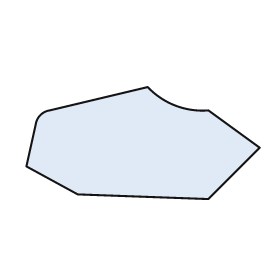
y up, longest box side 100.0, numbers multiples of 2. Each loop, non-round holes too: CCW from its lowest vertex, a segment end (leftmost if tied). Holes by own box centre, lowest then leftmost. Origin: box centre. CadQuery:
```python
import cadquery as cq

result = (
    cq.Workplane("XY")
    .moveTo(28.0, -24.0)
    .lineTo(50.0, -2.0)
    .lineTo(28.0, 14.0)
    .threePointArc((14.0, 16.0), (2.0, 24.0))
    .lineTo(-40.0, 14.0)
    .threePointArc((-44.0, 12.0), (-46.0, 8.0))
    .lineTo(-50.0, -10.0)
    .lineTo(-28.0, -22.0)
    .close()
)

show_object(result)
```